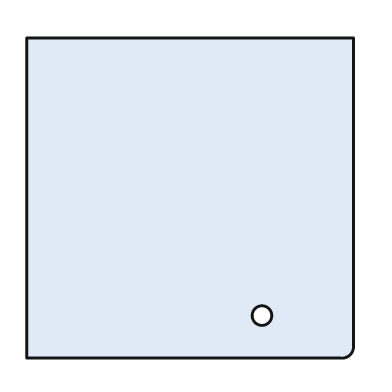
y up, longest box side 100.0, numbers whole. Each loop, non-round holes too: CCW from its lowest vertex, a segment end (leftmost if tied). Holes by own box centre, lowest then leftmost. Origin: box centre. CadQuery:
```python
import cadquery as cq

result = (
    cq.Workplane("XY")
    .moveTo(-50.0, -49.0)
    .lineTo(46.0, -49.0)
    .threePointArc((49.0, -48.0), (50.0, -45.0))
    .lineTo(50.0, 49.0)
    .lineTo(-50.0, 49.0)
    .close()
    .moveTo(22.0, -36.0)
    .circle(3.0)
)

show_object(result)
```